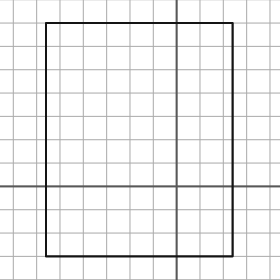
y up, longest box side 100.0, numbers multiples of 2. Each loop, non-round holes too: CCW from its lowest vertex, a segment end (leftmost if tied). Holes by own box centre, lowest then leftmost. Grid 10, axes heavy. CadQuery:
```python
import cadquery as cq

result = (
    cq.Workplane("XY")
    .moveTo(-56.0, -30.0)
    .lineTo(24.0, -30.0)
    .lineTo(24.0, 70.0)
    .lineTo(-56.0, 70.0)
    .close()
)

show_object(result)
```